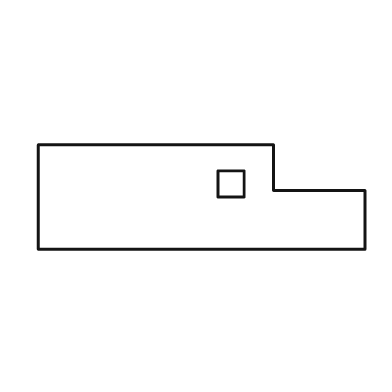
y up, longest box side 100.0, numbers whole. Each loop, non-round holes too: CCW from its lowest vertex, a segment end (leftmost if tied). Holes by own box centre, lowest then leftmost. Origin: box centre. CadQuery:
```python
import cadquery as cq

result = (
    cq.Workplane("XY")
    .moveTo(-50.0, -16.0)
    .lineTo(50.0, -16.0)
    .lineTo(50.0, 2.0)
    .lineTo(22.0, 2.0)
    .lineTo(22.0, 16.0)
    .lineTo(-50.0, 16.0)
    .close()
    .moveTo(5.0, 0.0)
    .lineTo(13.0, 0.0)
    .lineTo(13.0, 8.0)
    .lineTo(5.0, 8.0)
    .close()
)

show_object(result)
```